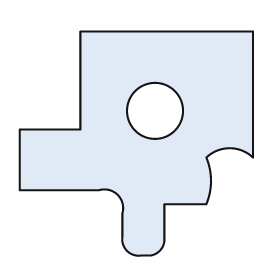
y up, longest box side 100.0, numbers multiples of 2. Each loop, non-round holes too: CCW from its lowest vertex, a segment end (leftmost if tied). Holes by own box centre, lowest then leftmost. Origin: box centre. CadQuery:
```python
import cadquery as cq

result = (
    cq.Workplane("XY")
    .moveTo(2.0, -48.0)
    .lineTo(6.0, -48.0)
    .threePointArc((10.0, -46.0), (12.0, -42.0))
    .lineTo(12.0, -26.0)
    .lineTo(30.0, -26.0)
    .threePointArc((32.0, -16.0), (30.0, -6.0))
    .threePointArc((40.0, -2.0), (50.0, -6.0))
    .lineTo(50.0, 48.0)
    .lineTo(-24.0, 48.0)
    .lineTo(-24.0, 6.0)
    .lineTo(-50.0, 6.0)
    .lineTo(-50.0, -20.0)
    .lineTo(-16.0, -20.0)
    .threePointArc((-8.0, -22.0), (-6.0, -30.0))
    .lineTo(-6.0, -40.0)
    .threePointArc((-4.0, -46.0), (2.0, -48.0))
    .close()
    .moveTo(8.0, 14.0)
    .circle(12.0)
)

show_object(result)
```